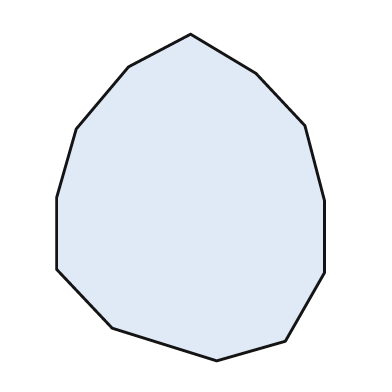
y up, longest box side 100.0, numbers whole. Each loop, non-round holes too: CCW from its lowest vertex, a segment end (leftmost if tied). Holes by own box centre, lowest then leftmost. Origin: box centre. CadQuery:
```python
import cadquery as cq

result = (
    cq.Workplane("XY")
    .moveTo(8.0, -50.0)
    .lineTo(29.0, -44.0)
    .lineTo(41.0, -23.0)
    .lineTo(41.0, -1.0)
    .lineTo(35.0, 22.0)
    .lineTo(20.0, 38.0)
    .lineTo(0.0, 50.0)
    .lineTo(-19.0, 40.0)
    .lineTo(-35.0, 21.0)
    .lineTo(-41.0, 0.0)
    .lineTo(-41.0, -22.0)
    .lineTo(-24.0, -40.0)
    .close()
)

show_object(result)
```